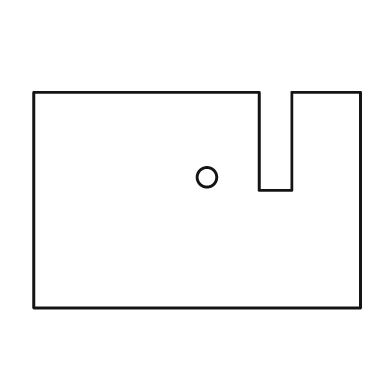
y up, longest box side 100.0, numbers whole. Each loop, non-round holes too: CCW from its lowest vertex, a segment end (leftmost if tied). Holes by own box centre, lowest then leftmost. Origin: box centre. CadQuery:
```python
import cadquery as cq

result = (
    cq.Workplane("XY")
    .moveTo(-50.0, -33.0)
    .lineTo(50.0, -33.0)
    .lineTo(50.0, 33.0)
    .lineTo(29.0, 33.0)
    .lineTo(29.0, 3.0)
    .lineTo(19.0, 3.0)
    .lineTo(19.0, 33.0)
    .lineTo(-50.0, 33.0)
    .close()
    .moveTo(3.0, 7.0)
    .circle(3.0)
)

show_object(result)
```